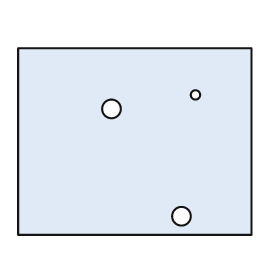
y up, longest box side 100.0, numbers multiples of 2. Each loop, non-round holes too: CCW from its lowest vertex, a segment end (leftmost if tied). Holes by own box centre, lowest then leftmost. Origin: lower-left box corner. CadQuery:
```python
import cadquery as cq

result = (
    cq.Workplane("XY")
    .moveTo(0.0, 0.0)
    .lineTo(100.0, 0.0)
    .lineTo(100.0, 80.0)
    .lineTo(0.0, 80.0)
    .close()
    .moveTo(70.0, 8.0)
    .circle(4.0)
    .moveTo(40.0, 54.0)
    .circle(4.0)
    .moveTo(76.0, 60.0)
    .circle(2.0)
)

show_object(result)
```